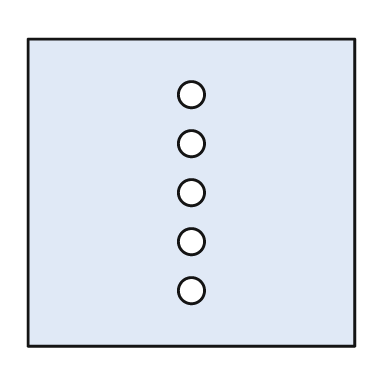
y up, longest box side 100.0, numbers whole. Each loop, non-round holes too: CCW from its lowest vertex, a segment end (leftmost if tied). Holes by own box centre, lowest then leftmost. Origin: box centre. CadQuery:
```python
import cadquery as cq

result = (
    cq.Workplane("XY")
    .moveTo(-50.0, -47.0)
    .lineTo(50.0, -47.0)
    .lineTo(50.0, 47.0)
    .lineTo(-50.0, 47.0)
    .close()
    .moveTo(0.0, -30.0)
    .circle(4.0)
    .moveTo(0.0, -15.0)
    .circle(4.0)
    .moveTo(0.0, 0.0)
    .circle(4.0)
    .moveTo(0.0, 15.0)
    .circle(4.0)
    .moveTo(0.0, 30.0)
    .circle(4.0)
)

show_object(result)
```